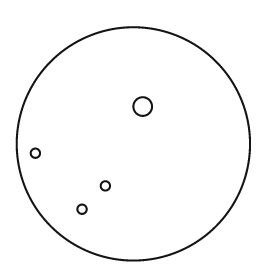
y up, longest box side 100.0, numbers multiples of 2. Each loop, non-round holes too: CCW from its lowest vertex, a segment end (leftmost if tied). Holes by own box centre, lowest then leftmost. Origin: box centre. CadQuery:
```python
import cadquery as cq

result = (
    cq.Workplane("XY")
    .moveTo(0.0, 0.0)
    .circle(50.0)
    .moveTo(-22.0, -28.0)
    .circle(2.0)
    .moveTo(-12.0, -18.0)
    .circle(2.0)
    .moveTo(-42.0, -4.0)
    .circle(2.0)
    .moveTo(4.0, 16.0)
    .circle(4.0)
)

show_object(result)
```